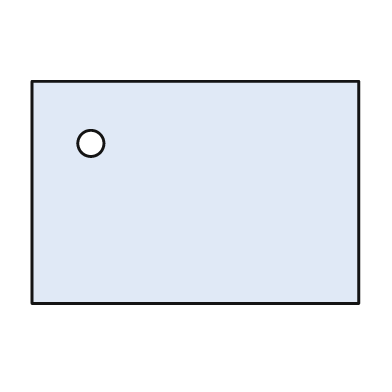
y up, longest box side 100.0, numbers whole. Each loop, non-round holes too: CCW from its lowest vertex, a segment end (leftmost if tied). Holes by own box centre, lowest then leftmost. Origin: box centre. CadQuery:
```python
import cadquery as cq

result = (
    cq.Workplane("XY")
    .moveTo(-50.0, -34.0)
    .lineTo(50.0, -34.0)
    .lineTo(50.0, 34.0)
    .lineTo(-50.0, 34.0)
    .close()
    .moveTo(-32.0, 15.0)
    .circle(4.0)
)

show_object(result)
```